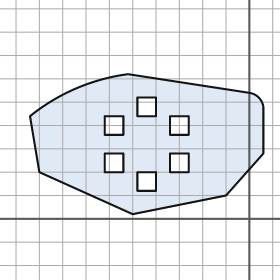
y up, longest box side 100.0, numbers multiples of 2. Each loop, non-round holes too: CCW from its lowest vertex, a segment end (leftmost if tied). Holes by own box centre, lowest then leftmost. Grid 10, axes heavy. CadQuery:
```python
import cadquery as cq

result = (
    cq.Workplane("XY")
    .moveTo(-50.0, 2.0)
    .lineTo(-10.0, 10.0)
    .lineTo(6.0, 28.0)
    .lineTo(6.0, 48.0)
    .threePointArc((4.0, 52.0), (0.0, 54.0))
    .lineTo(-52.0, 62.0)
    .threePointArc((-74.0, 56.0), (-94.0, 44.0))
    .lineTo(-90.0, 20.0)
    .close()
    .moveTo(-48.0, 12.0)
    .lineTo(-40.0, 12.0)
    .lineTo(-40.0, 20.0)
    .lineTo(-48.0, 20.0)
    .close()
    .moveTo(-62.0, 20.0)
    .lineTo(-54.0, 20.0)
    .lineTo(-54.0, 28.0)
    .lineTo(-62.0, 28.0)
    .close()
    .moveTo(-34.0, 20.0)
    .lineTo(-26.0, 20.0)
    .lineTo(-26.0, 28.0)
    .lineTo(-34.0, 28.0)
    .close()
    .moveTo(-62.0, 36.0)
    .lineTo(-54.0, 36.0)
    .lineTo(-54.0, 44.0)
    .lineTo(-62.0, 44.0)
    .close()
    .moveTo(-34.0, 36.0)
    .lineTo(-26.0, 36.0)
    .lineTo(-26.0, 44.0)
    .lineTo(-34.0, 44.0)
    .close()
    .moveTo(-48.0, 44.0)
    .lineTo(-40.0, 44.0)
    .lineTo(-40.0, 52.0)
    .lineTo(-48.0, 52.0)
    .close()
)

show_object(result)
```